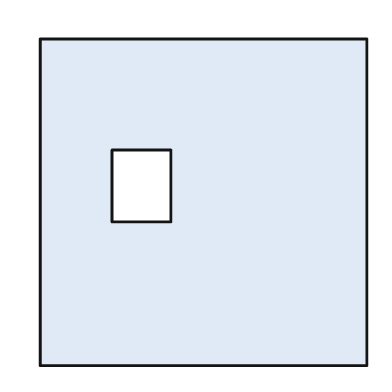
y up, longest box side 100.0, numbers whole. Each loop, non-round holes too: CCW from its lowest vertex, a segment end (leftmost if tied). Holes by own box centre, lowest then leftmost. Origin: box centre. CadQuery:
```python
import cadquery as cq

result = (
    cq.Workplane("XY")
    .moveTo(-50.0, -50.0)
    .lineTo(50.0, -50.0)
    .lineTo(50.0, 50.0)
    .lineTo(-50.0, 50.0)
    .close()
    .moveTo(-28.0, -6.0)
    .lineTo(-10.0, -6.0)
    .lineTo(-10.0, 16.0)
    .lineTo(-28.0, 16.0)
    .close()
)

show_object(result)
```